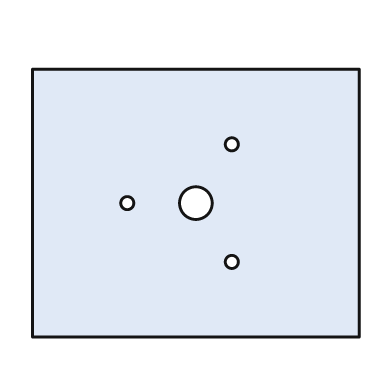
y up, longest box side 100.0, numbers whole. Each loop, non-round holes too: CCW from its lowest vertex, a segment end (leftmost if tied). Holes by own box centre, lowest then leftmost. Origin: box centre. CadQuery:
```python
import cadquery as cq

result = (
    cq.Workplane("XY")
    .moveTo(-50.0, -41.0)
    .lineTo(50.0, -41.0)
    .lineTo(50.0, 41.0)
    .lineTo(-50.0, 41.0)
    .close()
    .moveTo(11.0, -18.0)
    .circle(2.0)
    .moveTo(-21.0, 0.0)
    .circle(2.0)
    .moveTo(0.0, 0.0)
    .circle(5.0)
    .moveTo(11.0, 18.0)
    .circle(2.0)
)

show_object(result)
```